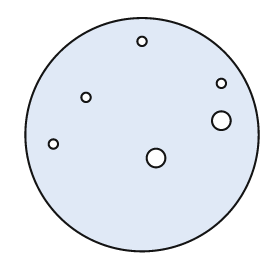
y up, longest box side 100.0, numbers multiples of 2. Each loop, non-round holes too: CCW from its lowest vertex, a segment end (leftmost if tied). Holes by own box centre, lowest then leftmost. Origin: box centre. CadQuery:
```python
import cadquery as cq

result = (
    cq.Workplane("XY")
    .moveTo(0.0, 0.0)
    .circle(50.0)
    .moveTo(6.0, -10.0)
    .circle(4.0)
    .moveTo(-38.0, -4.0)
    .circle(2.0)
    .moveTo(34.0, 6.0)
    .circle(4.0)
    .moveTo(-24.0, 16.0)
    .circle(2.0)
    .moveTo(34.0, 22.0)
    .circle(2.0)
    .moveTo(0.0, 40.0)
    .circle(2.0)
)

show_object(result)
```